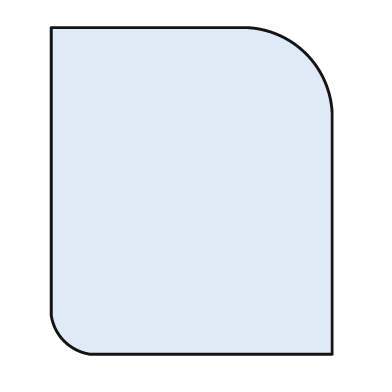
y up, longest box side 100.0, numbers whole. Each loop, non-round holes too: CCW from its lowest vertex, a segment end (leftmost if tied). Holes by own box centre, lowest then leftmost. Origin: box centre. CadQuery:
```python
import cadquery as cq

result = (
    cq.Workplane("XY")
    .moveTo(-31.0, -50.0)
    .lineTo(43.0, -50.0)
    .lineTo(43.0, 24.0)
    .threePointArc((35.0, 42.0), (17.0, 50.0))
    .lineTo(-43.0, 50.0)
    .lineTo(-43.0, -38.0)
    .threePointArc((-39.0, -46.0), (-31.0, -50.0))
    .close()
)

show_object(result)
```